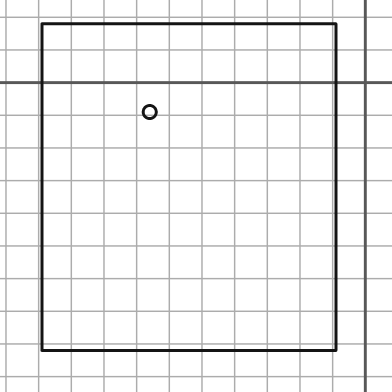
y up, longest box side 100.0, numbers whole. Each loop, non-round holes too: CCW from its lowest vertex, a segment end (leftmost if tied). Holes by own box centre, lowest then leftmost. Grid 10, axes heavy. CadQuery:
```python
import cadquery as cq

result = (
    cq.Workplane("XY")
    .moveTo(-99.0, -82.0)
    .lineTo(-9.0, -82.0)
    .lineTo(-9.0, 18.0)
    .lineTo(-99.0, 18.0)
    .close()
    .moveTo(-66.0, -9.0)
    .circle(2.0)
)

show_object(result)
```